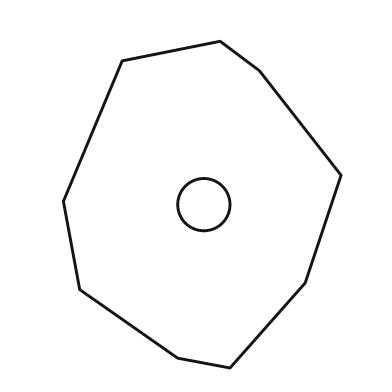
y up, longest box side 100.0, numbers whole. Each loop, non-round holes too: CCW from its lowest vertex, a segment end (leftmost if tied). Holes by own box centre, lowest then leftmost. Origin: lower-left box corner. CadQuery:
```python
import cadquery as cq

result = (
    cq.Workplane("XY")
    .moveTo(51.0, 0.0)
    .lineTo(74.0, 26.0)
    .lineTo(85.0, 59.0)
    .lineTo(60.0, 91.0)
    .lineTo(48.0, 100.0)
    .lineTo(18.0, 94.0)
    .lineTo(0.0, 51.0)
    .lineTo(5.0, 24.0)
    .lineTo(35.0, 3.0)
    .close()
    .moveTo(43.0, 50.0)
    .circle(8.0)
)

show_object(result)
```